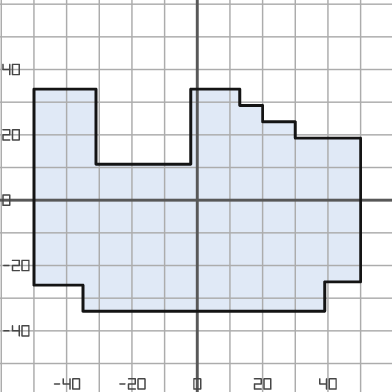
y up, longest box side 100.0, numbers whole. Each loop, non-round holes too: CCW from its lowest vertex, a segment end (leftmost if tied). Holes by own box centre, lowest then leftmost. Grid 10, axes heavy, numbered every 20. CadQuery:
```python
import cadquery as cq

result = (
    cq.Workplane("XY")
    .moveTo(-35.0, -34.0)
    .lineTo(39.0, -34.0)
    .lineTo(39.0, -25.0)
    .lineTo(50.0, -25.0)
    .lineTo(50.0, 19.0)
    .lineTo(30.0, 19.0)
    .lineTo(30.0, 24.0)
    .lineTo(20.0, 24.0)
    .lineTo(20.0, 29.0)
    .lineTo(13.0, 29.0)
    .lineTo(13.0, 34.0)
    .lineTo(-2.0, 34.0)
    .lineTo(-2.0, 11.0)
    .lineTo(-31.0, 11.0)
    .lineTo(-31.0, 34.0)
    .lineTo(-50.0, 34.0)
    .lineTo(-50.0, -26.0)
    .lineTo(-35.0, -26.0)
    .close()
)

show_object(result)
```